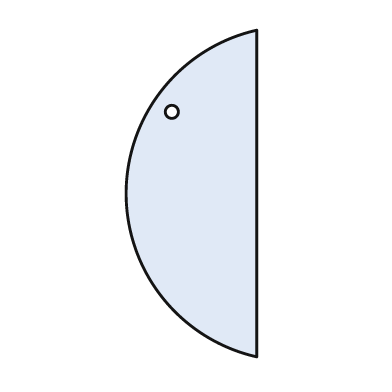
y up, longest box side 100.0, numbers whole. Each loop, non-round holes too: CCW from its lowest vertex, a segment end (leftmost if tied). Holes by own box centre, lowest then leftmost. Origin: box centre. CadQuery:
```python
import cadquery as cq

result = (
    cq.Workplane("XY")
    .moveTo(20.0, -50.0)
    .lineTo(20.0, 50.0)
    .threePointArc((-20.0, 0.0), (20.0, -50.0))
    .close()
    .moveTo(-6.0, 25.0)
    .circle(2.0)
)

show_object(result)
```